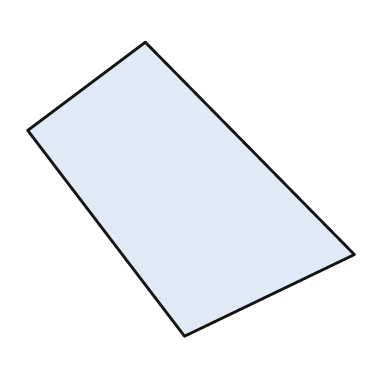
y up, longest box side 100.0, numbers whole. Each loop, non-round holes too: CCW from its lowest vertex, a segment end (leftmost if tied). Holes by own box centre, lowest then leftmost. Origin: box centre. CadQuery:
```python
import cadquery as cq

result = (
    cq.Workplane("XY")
    .moveTo(-2.0, -45.0)
    .lineTo(50.0, -20.0)
    .lineTo(-14.0, 45.0)
    .lineTo(-50.0, 18.0)
    .close()
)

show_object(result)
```